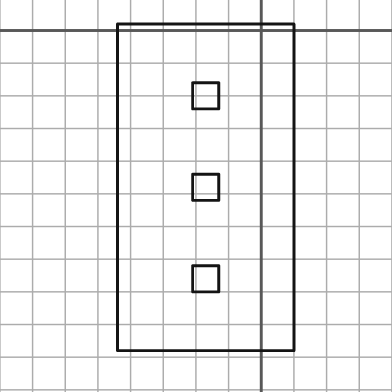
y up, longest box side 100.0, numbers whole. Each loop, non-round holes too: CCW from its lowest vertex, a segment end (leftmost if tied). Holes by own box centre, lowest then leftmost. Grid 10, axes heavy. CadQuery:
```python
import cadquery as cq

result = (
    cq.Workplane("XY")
    .moveTo(-44.0, -98.0)
    .lineTo(10.0, -98.0)
    .lineTo(10.0, 2.0)
    .lineTo(-44.0, 2.0)
    .close()
    .moveTo(-21.0, -80.0)
    .lineTo(-13.0, -80.0)
    .lineTo(-13.0, -72.0)
    .lineTo(-21.0, -72.0)
    .close()
    .moveTo(-21.0, -52.0)
    .lineTo(-13.0, -52.0)
    .lineTo(-13.0, -44.0)
    .lineTo(-21.0, -44.0)
    .close()
    .moveTo(-21.0, -24.0)
    .lineTo(-13.0, -24.0)
    .lineTo(-13.0, -16.0)
    .lineTo(-21.0, -16.0)
    .close()
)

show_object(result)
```